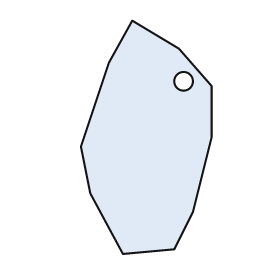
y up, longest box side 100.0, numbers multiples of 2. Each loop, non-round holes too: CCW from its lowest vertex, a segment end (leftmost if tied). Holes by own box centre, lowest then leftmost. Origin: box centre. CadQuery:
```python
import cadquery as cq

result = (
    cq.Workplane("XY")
    .moveTo(-10.0, -50.0)
    .lineTo(12.0, -48.0)
    .lineTo(20.0, -32.0)
    .lineTo(28.0, 0.0)
    .lineTo(28.0, 22.0)
    .lineTo(14.0, 38.0)
    .lineTo(-6.0, 50.0)
    .lineTo(-16.0, 32.0)
    .lineTo(-28.0, -4.0)
    .lineTo(-24.0, -24.0)
    .close()
    .moveTo(16.0, 24.0)
    .circle(4.0)
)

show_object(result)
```